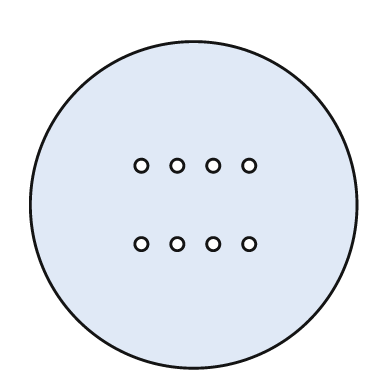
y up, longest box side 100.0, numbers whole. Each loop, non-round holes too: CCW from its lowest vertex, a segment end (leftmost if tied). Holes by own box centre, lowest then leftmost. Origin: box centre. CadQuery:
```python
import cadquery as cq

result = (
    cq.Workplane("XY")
    .moveTo(0.0, 0.0)
    .circle(50.0)
    .moveTo(-16.0, -12.0)
    .circle(2.0)
    .moveTo(-5.0, -12.0)
    .circle(2.0)
    .moveTo(6.0, -12.0)
    .circle(2.0)
    .moveTo(17.0, -12.0)
    .circle(2.0)
    .moveTo(-16.0, 12.0)
    .circle(2.0)
    .moveTo(-5.0, 12.0)
    .circle(2.0)
    .moveTo(6.0, 12.0)
    .circle(2.0)
    .moveTo(17.0, 12.0)
    .circle(2.0)
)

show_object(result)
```